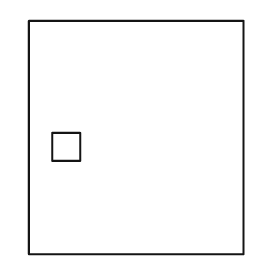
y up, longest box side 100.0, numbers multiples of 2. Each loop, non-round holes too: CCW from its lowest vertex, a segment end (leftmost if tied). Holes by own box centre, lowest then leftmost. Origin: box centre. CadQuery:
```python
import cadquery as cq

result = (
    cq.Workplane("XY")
    .moveTo(-46.0, -50.0)
    .lineTo(46.0, -50.0)
    .lineTo(46.0, 50.0)
    .lineTo(-46.0, 50.0)
    .close()
    .moveTo(-36.0, -10.0)
    .lineTo(-24.0, -10.0)
    .lineTo(-24.0, 2.0)
    .lineTo(-36.0, 2.0)
    .close()
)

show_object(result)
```